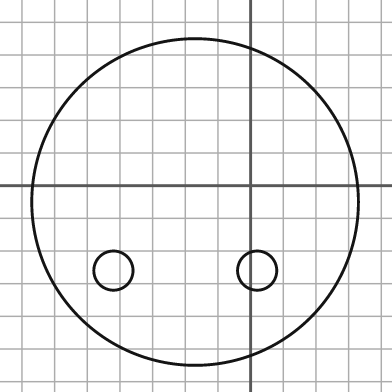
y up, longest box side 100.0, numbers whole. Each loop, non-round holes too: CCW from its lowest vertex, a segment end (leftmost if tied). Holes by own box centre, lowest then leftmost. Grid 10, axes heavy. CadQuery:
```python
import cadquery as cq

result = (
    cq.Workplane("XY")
    .moveTo(-17.0, -5.0)
    .circle(50.0)
    .moveTo(-42.0, -26.0)
    .circle(6.0)
    .moveTo(2.0, -26.0)
    .circle(6.0)
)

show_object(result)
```